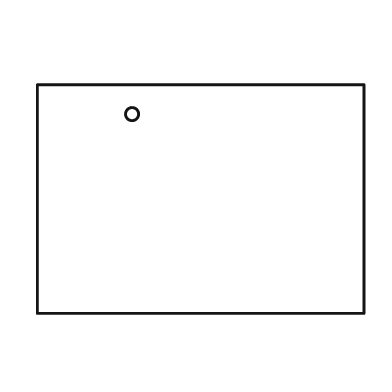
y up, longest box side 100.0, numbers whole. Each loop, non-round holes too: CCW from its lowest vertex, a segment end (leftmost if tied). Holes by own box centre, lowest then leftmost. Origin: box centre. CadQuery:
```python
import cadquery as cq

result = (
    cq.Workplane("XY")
    .moveTo(-50.0, -35.0)
    .lineTo(50.0, -35.0)
    .lineTo(50.0, 35.0)
    .lineTo(-50.0, 35.0)
    .close()
    .moveTo(-21.0, 26.0)
    .circle(2.0)
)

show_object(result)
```